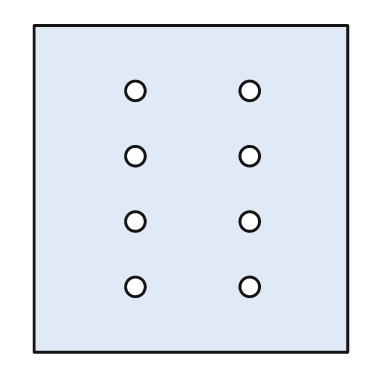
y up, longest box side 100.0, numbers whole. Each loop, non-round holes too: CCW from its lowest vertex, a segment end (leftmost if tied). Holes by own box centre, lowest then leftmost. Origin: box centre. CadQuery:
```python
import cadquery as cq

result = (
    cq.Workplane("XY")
    .moveTo(-48.0, -50.0)
    .lineTo(48.0, -50.0)
    .lineTo(48.0, 50.0)
    .lineTo(-48.0, 50.0)
    .close()
    .moveTo(-17.0, -30.0)
    .circle(3.0)
    .moveTo(18.0, -30.0)
    .circle(3.0)
    .moveTo(-17.0, -10.0)
    .circle(3.0)
    .moveTo(18.0, -10.0)
    .circle(3.0)
    .moveTo(-17.0, 10.0)
    .circle(3.0)
    .moveTo(18.0, 10.0)
    .circle(3.0)
    .moveTo(-17.0, 30.0)
    .circle(3.0)
    .moveTo(18.0, 30.0)
    .circle(3.0)
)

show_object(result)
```